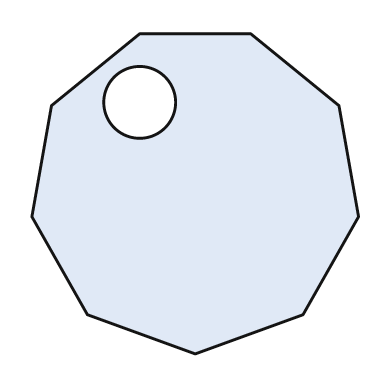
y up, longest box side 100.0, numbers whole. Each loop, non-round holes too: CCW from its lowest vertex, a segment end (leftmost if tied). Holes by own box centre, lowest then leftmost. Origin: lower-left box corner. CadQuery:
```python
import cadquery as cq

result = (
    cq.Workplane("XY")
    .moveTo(50.0, 0.0)
    .lineTo(83.0, 12.0)
    .lineTo(100.0, 42.0)
    .lineTo(94.0, 76.0)
    .lineTo(67.0, 98.0)
    .lineTo(33.0, 98.0)
    .lineTo(6.0, 76.0)
    .lineTo(0.0, 42.0)
    .lineTo(17.0, 12.0)
    .close()
    .moveTo(33.0, 77.0)
    .circle(11.0)
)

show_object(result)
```